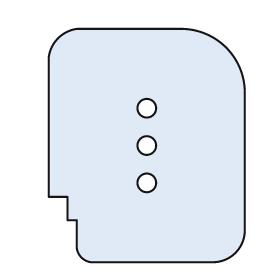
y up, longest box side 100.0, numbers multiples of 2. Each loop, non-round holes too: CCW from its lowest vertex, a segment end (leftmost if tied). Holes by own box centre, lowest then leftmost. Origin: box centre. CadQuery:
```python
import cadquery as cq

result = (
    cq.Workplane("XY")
    .moveTo(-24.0, -50.0)
    .lineTo(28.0, -50.0)
    .threePointArc((38.0, -46.0), (42.0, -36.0))
    .lineTo(42.0, 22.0)
    .threePointArc((34.0, 42.0), (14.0, 50.0))
    .lineTo(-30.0, 50.0)
    .threePointArc((-38.0, 46.0), (-42.0, 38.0))
    .lineTo(-42.0, -22.0)
    .lineTo(-34.0, -22.0)
    .lineTo(-34.0, -32.0)
    .lineTo(-30.0, -32.0)
    .lineTo(-30.0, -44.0)
    .threePointArc((-28.0, -48.0), (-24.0, -50.0))
    .close()
    .moveTo(0.0, -16.0)
    .circle(4.0)
    .moveTo(0.0, 0.0)
    .circle(4.0)
    .moveTo(0.0, 16.0)
    .circle(4.0)
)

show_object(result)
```